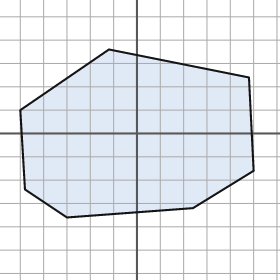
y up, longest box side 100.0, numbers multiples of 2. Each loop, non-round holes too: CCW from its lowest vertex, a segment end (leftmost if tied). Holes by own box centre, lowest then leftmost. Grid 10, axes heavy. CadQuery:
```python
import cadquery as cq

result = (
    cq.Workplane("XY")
    .moveTo(-30.0, -36.0)
    .lineTo(24.0, -32.0)
    .lineTo(50.0, -16.0)
    .lineTo(48.0, 24.0)
    .lineTo(-12.0, 36.0)
    .lineTo(-50.0, 10.0)
    .lineTo(-48.0, -24.0)
    .close()
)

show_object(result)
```